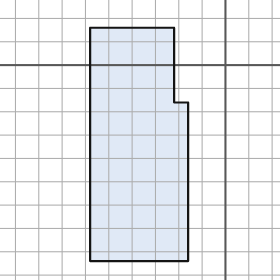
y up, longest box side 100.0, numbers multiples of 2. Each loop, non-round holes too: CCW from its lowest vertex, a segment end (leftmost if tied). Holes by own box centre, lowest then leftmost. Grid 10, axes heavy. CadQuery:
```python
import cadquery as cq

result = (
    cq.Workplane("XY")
    .moveTo(-58.0, -84.0)
    .lineTo(-16.0, -84.0)
    .lineTo(-16.0, -16.0)
    .lineTo(-22.0, -16.0)
    .lineTo(-22.0, 16.0)
    .lineTo(-58.0, 16.0)
    .close()
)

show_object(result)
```